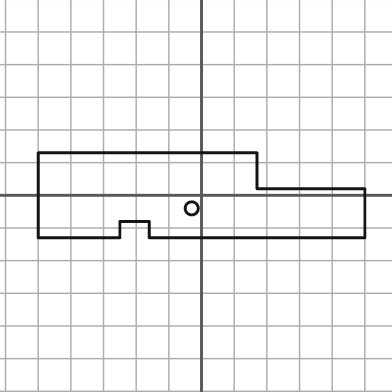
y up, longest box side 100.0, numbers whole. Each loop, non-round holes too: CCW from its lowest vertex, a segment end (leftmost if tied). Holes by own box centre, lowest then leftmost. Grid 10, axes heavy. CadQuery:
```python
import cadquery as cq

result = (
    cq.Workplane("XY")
    .moveTo(-50.0, -13.0)
    .lineTo(-25.0, -13.0)
    .lineTo(-25.0, -8.0)
    .lineTo(-16.0, -8.0)
    .lineTo(-16.0, -13.0)
    .lineTo(50.0, -13.0)
    .lineTo(50.0, 2.0)
    .lineTo(17.0, 2.0)
    .lineTo(17.0, 13.0)
    .lineTo(-50.0, 13.0)
    .close()
    .moveTo(-3.0, -4.0)
    .circle(2.0)
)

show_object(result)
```